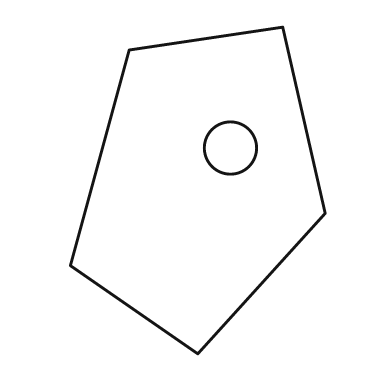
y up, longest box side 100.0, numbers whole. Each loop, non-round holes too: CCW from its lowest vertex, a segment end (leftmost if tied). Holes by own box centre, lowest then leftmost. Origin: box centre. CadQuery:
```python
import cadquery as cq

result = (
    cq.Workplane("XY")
    .moveTo(0.0, -50.0)
    .lineTo(39.0, -7.0)
    .lineTo(26.0, 50.0)
    .lineTo(-21.0, 43.0)
    .lineTo(-39.0, -23.0)
    .close()
    .moveTo(10.0, 13.0)
    .circle(8.0)
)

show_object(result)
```